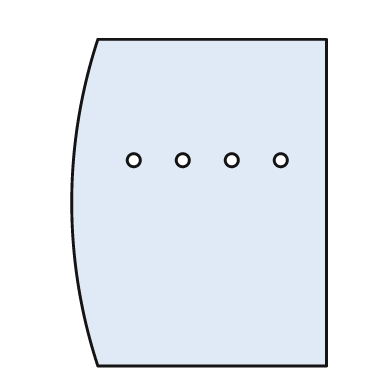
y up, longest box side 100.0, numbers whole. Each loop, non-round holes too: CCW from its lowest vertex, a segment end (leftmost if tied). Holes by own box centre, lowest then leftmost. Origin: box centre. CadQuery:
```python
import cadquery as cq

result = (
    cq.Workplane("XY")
    .moveTo(-31.0, -50.0)
    .lineTo(39.0, -50.0)
    .lineTo(39.0, 50.0)
    .lineTo(-31.0, 50.0)
    .threePointArc((-39.0, 0.0), (-31.0, -50.0))
    .close()
    .moveTo(-20.0, 13.0)
    .circle(2.0)
    .moveTo(-5.0, 13.0)
    .circle(2.0)
    .moveTo(10.0, 13.0)
    .circle(2.0)
    .moveTo(25.0, 13.0)
    .circle(2.0)
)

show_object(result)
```